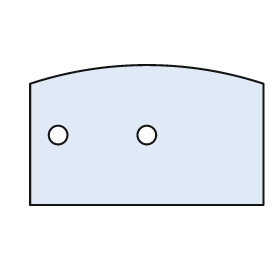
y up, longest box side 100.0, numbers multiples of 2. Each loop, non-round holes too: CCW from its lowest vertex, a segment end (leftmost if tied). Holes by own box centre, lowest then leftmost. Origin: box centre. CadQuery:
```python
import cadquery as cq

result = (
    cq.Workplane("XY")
    .moveTo(-50.0, -30.0)
    .lineTo(50.0, -30.0)
    .lineTo(50.0, 22.0)
    .threePointArc((0.0, 30.0), (-50.0, 22.0))
    .close()
    .moveTo(-38.0, 0.0)
    .circle(4.0)
    .moveTo(0.0, 0.0)
    .circle(4.0)
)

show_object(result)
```